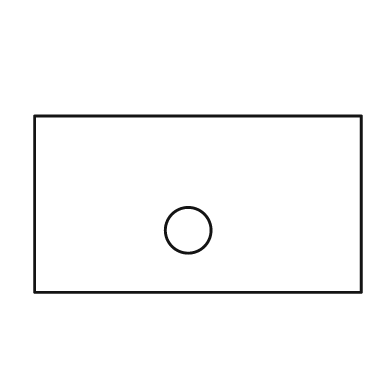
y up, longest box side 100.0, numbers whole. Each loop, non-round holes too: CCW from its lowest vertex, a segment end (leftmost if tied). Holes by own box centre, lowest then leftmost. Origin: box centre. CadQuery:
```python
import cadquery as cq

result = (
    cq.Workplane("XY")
    .moveTo(-50.0, -27.0)
    .lineTo(50.0, -27.0)
    .lineTo(50.0, 27.0)
    .lineTo(-50.0, 27.0)
    .close()
    .moveTo(-3.0, -8.0)
    .circle(7.0)
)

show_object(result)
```